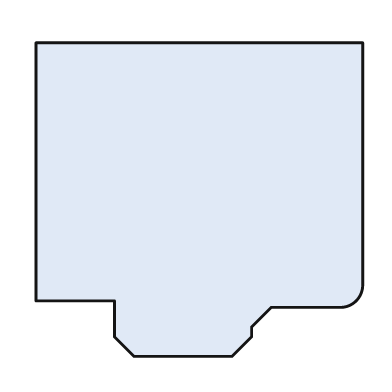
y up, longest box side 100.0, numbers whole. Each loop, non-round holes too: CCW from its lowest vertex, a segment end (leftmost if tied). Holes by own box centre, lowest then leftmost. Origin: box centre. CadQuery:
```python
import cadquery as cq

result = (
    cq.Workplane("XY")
    .moveTo(-20.0, -48.0)
    .lineTo(10.0, -48.0)
    .lineTo(16.0, -42.0)
    .lineTo(16.0, -39.0)
    .lineTo(22.0, -33.0)
    .lineTo(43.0, -33.0)
    .threePointArc((48.0, -31.0), (50.0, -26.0))
    .lineTo(50.0, 48.0)
    .lineTo(-50.0, 48.0)
    .lineTo(-50.0, -31.0)
    .lineTo(-26.0, -31.0)
    .lineTo(-26.0, -42.0)
    .close()
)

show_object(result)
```